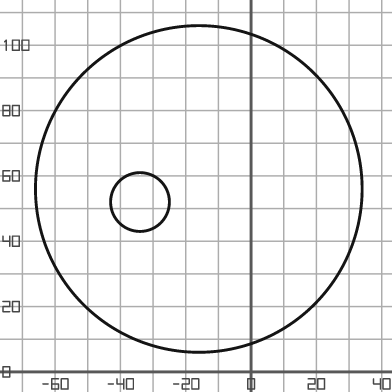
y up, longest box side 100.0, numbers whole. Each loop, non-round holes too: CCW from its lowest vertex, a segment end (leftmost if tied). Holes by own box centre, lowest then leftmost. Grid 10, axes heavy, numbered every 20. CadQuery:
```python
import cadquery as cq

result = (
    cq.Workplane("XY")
    .moveTo(-16.0, 56.0)
    .circle(50.0)
    .moveTo(-34.0, 52.0)
    .circle(9.0)
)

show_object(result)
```